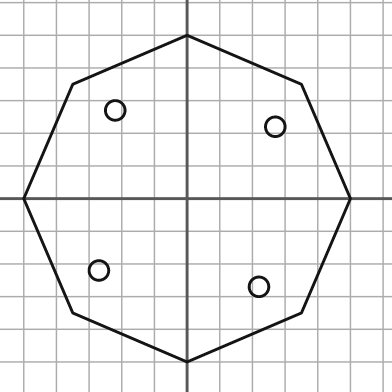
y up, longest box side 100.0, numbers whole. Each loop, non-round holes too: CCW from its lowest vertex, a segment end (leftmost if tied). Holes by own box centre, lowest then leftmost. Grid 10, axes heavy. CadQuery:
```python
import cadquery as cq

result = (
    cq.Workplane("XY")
    .moveTo(0.0, -50.0)
    .lineTo(35.0, -35.0)
    .lineTo(50.0, 0.0)
    .lineTo(35.0, 35.0)
    .lineTo(0.0, 50.0)
    .lineTo(-35.0, 35.0)
    .lineTo(-50.0, 0.0)
    .lineTo(-35.0, -35.0)
    .close()
    .moveTo(22.0, -27.0)
    .circle(3.0)
    .moveTo(-27.0, -22.0)
    .circle(3.0)
    .moveTo(27.0, 22.0)
    .circle(3.0)
    .moveTo(-22.0, 27.0)
    .circle(3.0)
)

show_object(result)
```